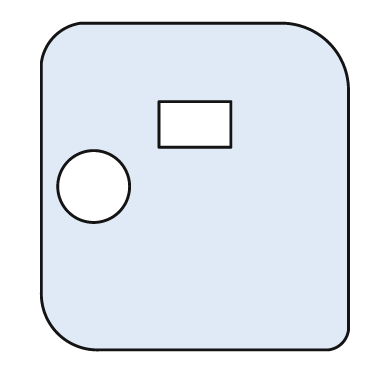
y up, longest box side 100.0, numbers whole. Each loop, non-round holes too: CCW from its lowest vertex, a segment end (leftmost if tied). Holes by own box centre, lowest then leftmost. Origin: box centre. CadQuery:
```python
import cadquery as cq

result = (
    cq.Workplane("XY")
    .moveTo(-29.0, -50.0)
    .lineTo(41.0, -50.0)
    .threePointArc((45.0, -48.0), (47.0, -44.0))
    .lineTo(47.0, 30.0)
    .threePointArc((41.0, 44.0), (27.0, 50.0))
    .lineTo(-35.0, 50.0)
    .threePointArc((-43.0, 46.0), (-47.0, 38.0))
    .lineTo(-47.0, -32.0)
    .threePointArc((-42.0, -45.0), (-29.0, -50.0))
    .close()
    .moveTo(-31.0, 0.0)
    .circle(11.0)
    .moveTo(-11.0, 12.0)
    .lineTo(11.0, 12.0)
    .lineTo(11.0, 26.0)
    .lineTo(-11.0, 26.0)
    .close()
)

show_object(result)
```